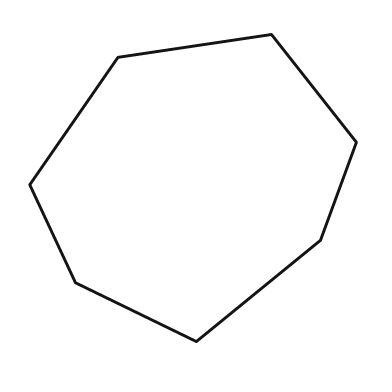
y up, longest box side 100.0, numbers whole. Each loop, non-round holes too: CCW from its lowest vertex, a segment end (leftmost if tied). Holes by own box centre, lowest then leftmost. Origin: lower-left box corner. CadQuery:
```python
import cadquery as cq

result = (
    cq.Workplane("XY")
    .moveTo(51.0, 0.0)
    .lineTo(89.0, 31.0)
    .lineTo(100.0, 61.0)
    .lineTo(74.0, 94.0)
    .lineTo(27.0, 87.0)
    .lineTo(0.0, 48.0)
    .lineTo(14.0, 18.0)
    .close()
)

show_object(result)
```